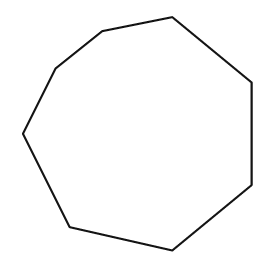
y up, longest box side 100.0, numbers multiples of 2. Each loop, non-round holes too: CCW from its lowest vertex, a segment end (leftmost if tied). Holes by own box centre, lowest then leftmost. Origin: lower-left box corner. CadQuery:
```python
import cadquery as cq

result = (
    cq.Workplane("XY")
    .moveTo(64.0, 0.0)
    .lineTo(98.0, 28.0)
    .lineTo(98.0, 72.0)
    .lineTo(64.0, 100.0)
    .lineTo(34.0, 94.0)
    .lineTo(14.0, 78.0)
    .lineTo(0.0, 50.0)
    .lineTo(20.0, 10.0)
    .close()
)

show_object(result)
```